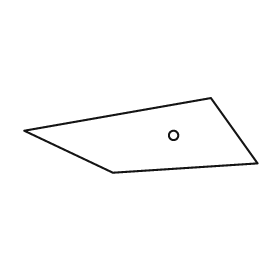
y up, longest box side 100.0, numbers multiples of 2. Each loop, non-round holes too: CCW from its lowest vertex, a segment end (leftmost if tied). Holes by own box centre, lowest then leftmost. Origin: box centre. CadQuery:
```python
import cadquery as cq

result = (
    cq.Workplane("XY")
    .moveTo(-12.0, -16.0)
    .lineTo(50.0, -12.0)
    .lineTo(30.0, 16.0)
    .lineTo(-50.0, 2.0)
    .close()
    .moveTo(14.0, 0.0)
    .circle(2.0)
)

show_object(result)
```